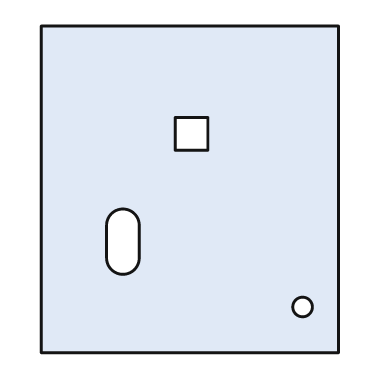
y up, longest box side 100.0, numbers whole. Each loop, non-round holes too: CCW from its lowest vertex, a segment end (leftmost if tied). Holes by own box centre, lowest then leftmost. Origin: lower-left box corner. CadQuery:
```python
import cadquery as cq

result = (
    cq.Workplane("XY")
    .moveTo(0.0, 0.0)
    .lineTo(91.0, 0.0)
    .lineTo(91.0, 100.0)
    .lineTo(0.0, 100.0)
    .close()
    .moveTo(80.0, 14.0)
    .circle(3.0)
    .moveTo(20.0, 29.0)
    .threePointArc((25.0, 24.0), (30.0, 29.0))
    .lineTo(30.0, 39.0)
    .threePointArc((25.0, 44.0), (20.0, 39.0))
    .close()
    .moveTo(41.0, 62.0)
    .lineTo(51.0, 62.0)
    .lineTo(51.0, 72.0)
    .lineTo(41.0, 72.0)
    .close()
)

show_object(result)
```